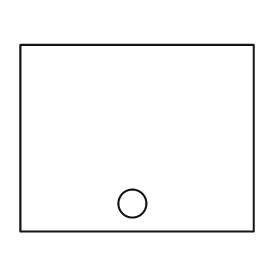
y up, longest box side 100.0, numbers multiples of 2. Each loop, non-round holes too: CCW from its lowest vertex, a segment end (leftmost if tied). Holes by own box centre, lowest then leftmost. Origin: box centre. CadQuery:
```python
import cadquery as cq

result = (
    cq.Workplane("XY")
    .moveTo(-50.0, -40.0)
    .lineTo(50.0, -40.0)
    .lineTo(50.0, 40.0)
    .lineTo(-50.0, 40.0)
    .close()
    .moveTo(-2.0, -28.0)
    .circle(6.0)
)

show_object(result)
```